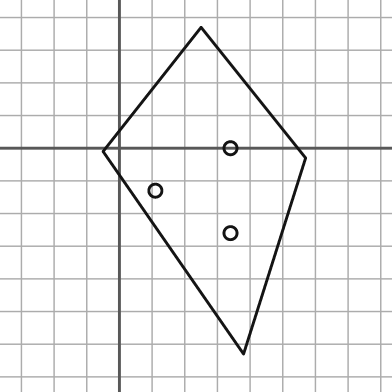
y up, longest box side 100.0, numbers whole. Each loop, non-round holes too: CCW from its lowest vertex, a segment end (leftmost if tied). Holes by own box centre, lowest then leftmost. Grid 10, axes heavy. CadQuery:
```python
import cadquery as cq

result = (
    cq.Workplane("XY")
    .moveTo(38.0, -63.0)
    .lineTo(57.0, -3.0)
    .lineTo(25.0, 37.0)
    .lineTo(-5.0, -1.0)
    .close()
    .moveTo(34.0, -26.0)
    .circle(2.0)
    .moveTo(11.0, -13.0)
    .circle(2.0)
    .moveTo(34.0, 0.0)
    .circle(2.0)
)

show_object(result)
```